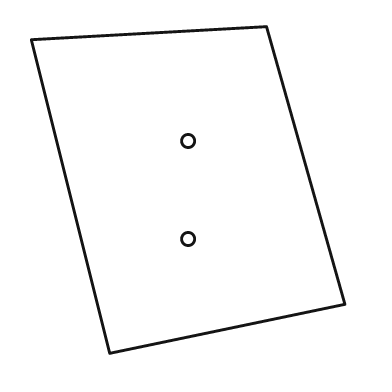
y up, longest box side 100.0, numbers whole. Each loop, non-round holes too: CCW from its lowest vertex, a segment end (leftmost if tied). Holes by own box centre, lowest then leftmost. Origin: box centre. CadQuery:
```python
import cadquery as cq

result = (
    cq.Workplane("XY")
    .moveTo(-24.0, -50.0)
    .lineTo(48.0, -35.0)
    .lineTo(24.0, 50.0)
    .lineTo(-48.0, 46.0)
    .close()
    .moveTo(0.0, -15.0)
    .circle(2.0)
    .moveTo(0.0, 15.0)
    .circle(2.0)
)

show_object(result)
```